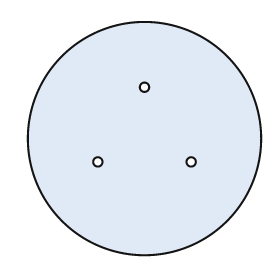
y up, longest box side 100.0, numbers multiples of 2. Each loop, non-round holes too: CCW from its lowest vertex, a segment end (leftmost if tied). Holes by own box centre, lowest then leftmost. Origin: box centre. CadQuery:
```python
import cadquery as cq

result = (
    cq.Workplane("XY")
    .moveTo(0.0, 0.0)
    .circle(50.0)
    .moveTo(-20.0, -10.0)
    .circle(2.0)
    .moveTo(20.0, -10.0)
    .circle(2.0)
    .moveTo(0.0, 22.0)
    .circle(2.0)
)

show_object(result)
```